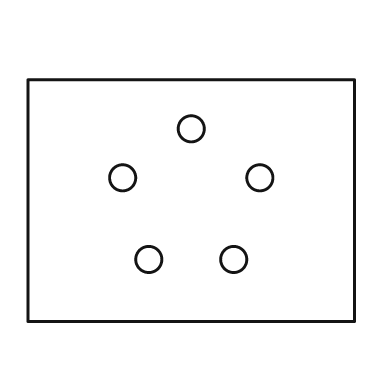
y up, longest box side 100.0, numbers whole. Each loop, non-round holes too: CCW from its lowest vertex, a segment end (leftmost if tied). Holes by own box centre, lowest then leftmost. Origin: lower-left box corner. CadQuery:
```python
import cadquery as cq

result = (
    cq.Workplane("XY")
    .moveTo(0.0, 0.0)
    .lineTo(100.0, 0.0)
    .lineTo(100.0, 74.0)
    .lineTo(0.0, 74.0)
    .close()
    .moveTo(37.0, 19.0)
    .circle(4.0)
    .moveTo(63.0, 19.0)
    .circle(4.0)
    .moveTo(29.0, 44.0)
    .circle(4.0)
    .moveTo(71.0, 44.0)
    .circle(4.0)
    .moveTo(50.0, 59.0)
    .circle(4.0)
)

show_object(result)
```